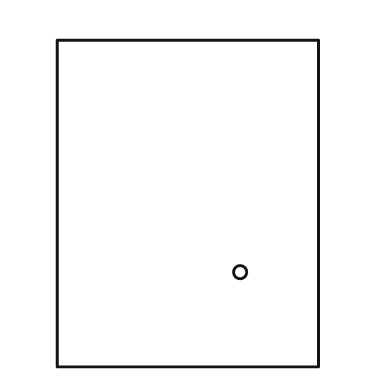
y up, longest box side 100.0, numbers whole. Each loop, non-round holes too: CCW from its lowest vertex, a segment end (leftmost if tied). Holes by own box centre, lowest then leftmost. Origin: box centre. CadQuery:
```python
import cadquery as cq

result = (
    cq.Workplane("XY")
    .moveTo(-40.0, -50.0)
    .lineTo(40.0, -50.0)
    .lineTo(40.0, 50.0)
    .lineTo(-40.0, 50.0)
    .close()
    .moveTo(16.0, -21.0)
    .circle(2.0)
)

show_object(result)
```